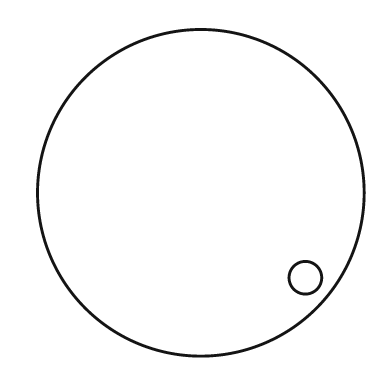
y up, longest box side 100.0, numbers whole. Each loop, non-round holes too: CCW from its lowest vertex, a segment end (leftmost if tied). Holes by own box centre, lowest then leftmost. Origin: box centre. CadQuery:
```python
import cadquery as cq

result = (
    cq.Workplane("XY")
    .moveTo(0.0, 0.0)
    .circle(50.0)
    .moveTo(32.0, -26.0)
    .circle(5.0)
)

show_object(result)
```